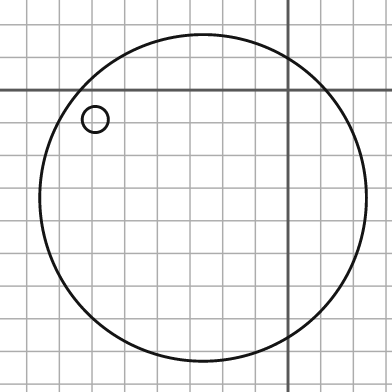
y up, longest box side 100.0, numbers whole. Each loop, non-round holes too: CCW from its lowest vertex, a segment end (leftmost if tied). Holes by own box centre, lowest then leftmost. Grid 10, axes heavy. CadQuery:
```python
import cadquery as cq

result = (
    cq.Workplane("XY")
    .moveTo(-26.0, -33.0)
    .circle(50.0)
    .moveTo(-59.0, -9.0)
    .circle(4.0)
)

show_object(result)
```